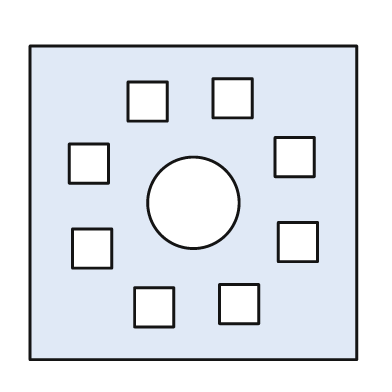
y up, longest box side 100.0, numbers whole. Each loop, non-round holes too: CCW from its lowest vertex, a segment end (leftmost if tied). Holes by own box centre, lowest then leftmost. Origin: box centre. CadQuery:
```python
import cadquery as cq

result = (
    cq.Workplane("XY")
    .moveTo(-50.0, -48.0)
    .lineTo(50.0, -48.0)
    .lineTo(50.0, 48.0)
    .lineTo(-50.0, 48.0)
    .close()
    .moveTo(-18.0, -38.0)
    .lineTo(-6.0, -38.0)
    .lineTo(-6.0, -26.0)
    .lineTo(-18.0, -26.0)
    .close()
    .moveTo(8.0, -37.0)
    .lineTo(20.0, -37.0)
    .lineTo(20.0, -25.0)
    .lineTo(8.0, -25.0)
    .close()
    .moveTo(-37.0, -20.0)
    .lineTo(-25.0, -20.0)
    .lineTo(-25.0, -8.0)
    .lineTo(-37.0, -8.0)
    .close()
    .moveTo(26.0, -18.0)
    .lineTo(38.0, -18.0)
    .lineTo(38.0, -6.0)
    .lineTo(26.0, -6.0)
    .close()
    .moveTo(0.0, 0.0)
    .circle(14.0)
    .moveTo(-38.0, 6.0)
    .lineTo(-26.0, 6.0)
    .lineTo(-26.0, 18.0)
    .lineTo(-38.0, 18.0)
    .close()
    .moveTo(25.0, 8.0)
    .lineTo(37.0, 8.0)
    .lineTo(37.0, 20.0)
    .lineTo(25.0, 20.0)
    .close()
    .moveTo(-20.0, 25.0)
    .lineTo(-8.0, 25.0)
    .lineTo(-8.0, 37.0)
    .lineTo(-20.0, 37.0)
    .close()
    .moveTo(6.0, 26.0)
    .lineTo(18.0, 26.0)
    .lineTo(18.0, 38.0)
    .lineTo(6.0, 38.0)
    .close()
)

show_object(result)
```